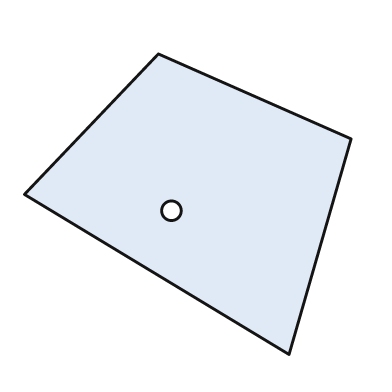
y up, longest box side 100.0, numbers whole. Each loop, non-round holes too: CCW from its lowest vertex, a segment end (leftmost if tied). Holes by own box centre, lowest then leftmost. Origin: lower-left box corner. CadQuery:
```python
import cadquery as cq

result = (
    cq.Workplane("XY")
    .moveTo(81.0, 0.0)
    .lineTo(100.0, 66.0)
    .lineTo(41.0, 92.0)
    .lineTo(0.0, 49.0)
    .close()
    .moveTo(45.0, 44.0)
    .circle(3.0)
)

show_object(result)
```